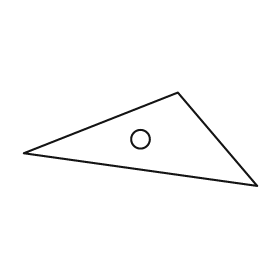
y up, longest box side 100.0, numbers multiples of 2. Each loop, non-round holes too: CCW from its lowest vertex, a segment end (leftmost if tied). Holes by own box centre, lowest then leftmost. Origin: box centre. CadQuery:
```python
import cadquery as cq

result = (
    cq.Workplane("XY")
    .moveTo(50.0, -20.0)
    .lineTo(16.0, 20.0)
    .lineTo(-50.0, -6.0)
    .close()
    .moveTo(0.0, 0.0)
    .circle(4.0)
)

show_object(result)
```